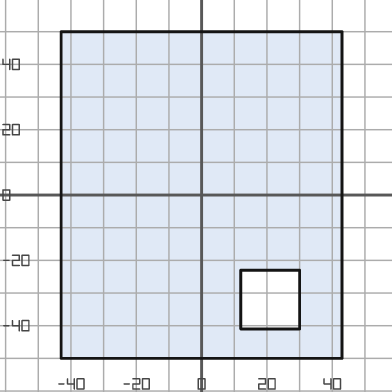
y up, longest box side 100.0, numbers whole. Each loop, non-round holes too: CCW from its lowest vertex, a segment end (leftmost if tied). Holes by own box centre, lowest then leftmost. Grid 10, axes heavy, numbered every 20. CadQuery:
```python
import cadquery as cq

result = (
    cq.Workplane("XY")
    .moveTo(-43.0, -50.0)
    .lineTo(43.0, -50.0)
    .lineTo(43.0, 50.0)
    .lineTo(-43.0, 50.0)
    .close()
    .moveTo(12.0, -41.0)
    .lineTo(30.0, -41.0)
    .lineTo(30.0, -23.0)
    .lineTo(12.0, -23.0)
    .close()
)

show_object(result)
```